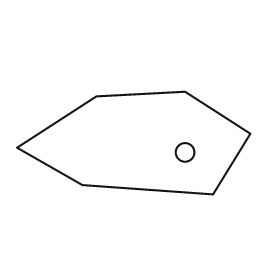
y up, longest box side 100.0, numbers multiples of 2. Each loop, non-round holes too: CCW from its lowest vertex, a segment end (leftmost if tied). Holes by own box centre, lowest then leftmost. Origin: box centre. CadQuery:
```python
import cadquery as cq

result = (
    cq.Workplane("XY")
    .moveTo(34.0, -22.0)
    .lineTo(50.0, 4.0)
    .lineTo(22.0, 22.0)
    .lineTo(-16.0, 20.0)
    .lineTo(-50.0, -2.0)
    .lineTo(-22.0, -18.0)
    .close()
    .moveTo(22.0, -4.0)
    .circle(4.0)
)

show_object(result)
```